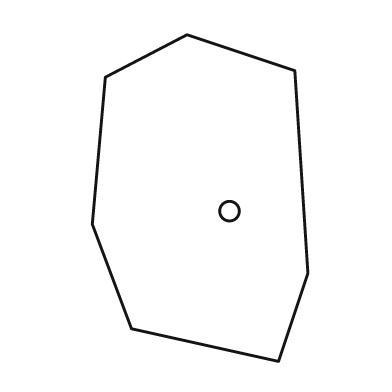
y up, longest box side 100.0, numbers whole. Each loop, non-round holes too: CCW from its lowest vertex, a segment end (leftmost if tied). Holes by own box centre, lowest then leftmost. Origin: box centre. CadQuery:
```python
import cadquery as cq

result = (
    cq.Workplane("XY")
    .moveTo(24.0, -50.0)
    .lineTo(33.0, -23.0)
    .lineTo(29.0, 39.0)
    .lineTo(-4.0, 50.0)
    .lineTo(-29.0, 37.0)
    .lineTo(-33.0, -8.0)
    .lineTo(-21.0, -40.0)
    .close()
    .moveTo(9.0, -4.0)
    .circle(3.0)
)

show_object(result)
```